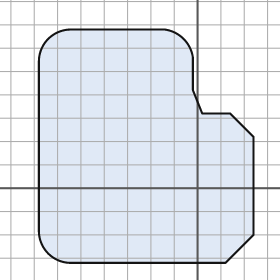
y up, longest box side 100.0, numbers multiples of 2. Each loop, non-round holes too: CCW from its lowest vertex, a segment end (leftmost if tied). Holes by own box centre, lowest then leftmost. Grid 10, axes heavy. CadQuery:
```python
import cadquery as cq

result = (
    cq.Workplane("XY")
    .moveTo(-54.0, -32.0)
    .lineTo(12.0, -32.0)
    .lineTo(24.0, -20.0)
    .lineTo(24.0, 22.0)
    .lineTo(14.0, 32.0)
    .lineTo(2.0, 32.0)
    .lineTo(-2.0, 42.0)
    .lineTo(-2.0, 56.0)
    .threePointArc((-6.0, 64.0), (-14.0, 68.0))
    .lineTo(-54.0, 68.0)
    .threePointArc((-64.0, 64.0), (-68.0, 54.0))
    .lineTo(-68.0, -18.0)
    .threePointArc((-64.0, -28.0), (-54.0, -32.0))
    .close()
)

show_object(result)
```